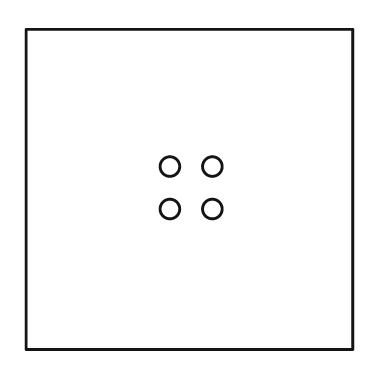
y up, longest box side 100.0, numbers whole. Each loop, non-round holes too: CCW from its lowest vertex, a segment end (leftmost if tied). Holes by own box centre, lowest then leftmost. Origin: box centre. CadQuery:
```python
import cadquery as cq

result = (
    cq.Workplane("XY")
    .moveTo(-50.0, -49.0)
    .lineTo(50.0, -49.0)
    .lineTo(50.0, 49.0)
    .lineTo(-50.0, 49.0)
    .close()
    .moveTo(-6.0, -6.0)
    .circle(3.0)
    .moveTo(7.0, -6.0)
    .circle(3.0)
    .moveTo(-6.0, 7.0)
    .circle(3.0)
    .moveTo(7.0, 7.0)
    .circle(3.0)
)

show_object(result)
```